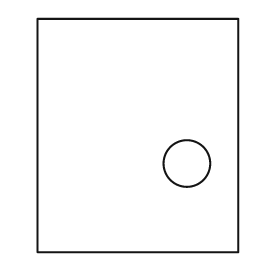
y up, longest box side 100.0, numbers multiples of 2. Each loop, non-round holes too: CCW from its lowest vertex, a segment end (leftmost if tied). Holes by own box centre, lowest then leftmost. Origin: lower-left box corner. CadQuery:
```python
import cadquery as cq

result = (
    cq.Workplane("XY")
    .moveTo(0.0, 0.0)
    .lineTo(86.0, 0.0)
    .lineTo(86.0, 100.0)
    .lineTo(0.0, 100.0)
    .close()
    .moveTo(64.0, 38.0)
    .circle(10.0)
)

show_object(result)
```